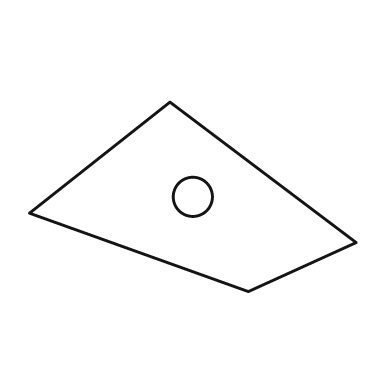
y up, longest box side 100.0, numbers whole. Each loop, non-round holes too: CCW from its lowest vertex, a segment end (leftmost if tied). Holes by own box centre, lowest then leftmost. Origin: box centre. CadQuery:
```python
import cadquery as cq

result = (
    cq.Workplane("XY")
    .moveTo(17.0, -29.0)
    .lineTo(50.0, -14.0)
    .lineTo(-7.0, 29.0)
    .lineTo(-50.0, -5.0)
    .close()
    .moveTo(0.0, 0.0)
    .circle(6.0)
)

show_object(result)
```